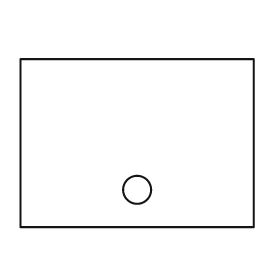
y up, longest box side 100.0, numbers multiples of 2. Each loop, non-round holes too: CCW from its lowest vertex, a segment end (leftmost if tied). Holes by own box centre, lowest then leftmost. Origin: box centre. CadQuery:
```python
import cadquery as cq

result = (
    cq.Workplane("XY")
    .moveTo(-50.0, -36.0)
    .lineTo(50.0, -36.0)
    .lineTo(50.0, 36.0)
    .lineTo(-50.0, 36.0)
    .close()
    .moveTo(0.0, -20.0)
    .circle(6.0)
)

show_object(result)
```